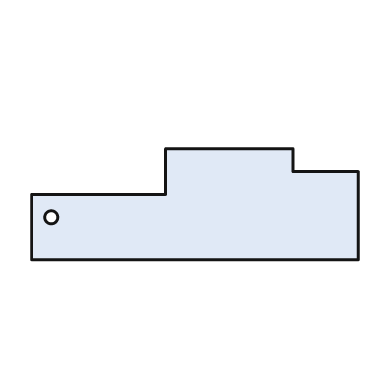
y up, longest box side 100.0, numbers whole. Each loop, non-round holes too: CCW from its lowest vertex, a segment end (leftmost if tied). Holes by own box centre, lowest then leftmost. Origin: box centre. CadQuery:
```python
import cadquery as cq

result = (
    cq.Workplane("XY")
    .moveTo(-50.0, -17.0)
    .lineTo(50.0, -17.0)
    .lineTo(50.0, 10.0)
    .lineTo(30.0, 10.0)
    .lineTo(30.0, 17.0)
    .lineTo(-9.0, 17.0)
    .lineTo(-9.0, 3.0)
    .lineTo(-50.0, 3.0)
    .close()
    .moveTo(-44.0, -4.0)
    .circle(2.0)
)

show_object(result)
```